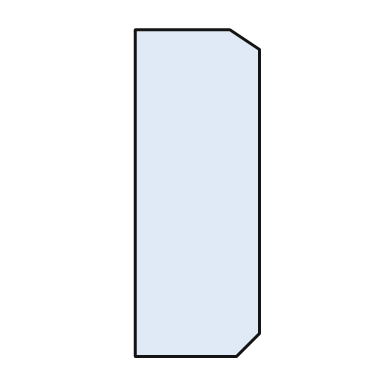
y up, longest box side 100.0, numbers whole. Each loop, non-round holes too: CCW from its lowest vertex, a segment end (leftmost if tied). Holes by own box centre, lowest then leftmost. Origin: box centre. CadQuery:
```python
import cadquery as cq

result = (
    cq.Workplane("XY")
    .moveTo(-19.0, -50.0)
    .lineTo(12.0, -50.0)
    .lineTo(19.0, -43.0)
    .lineTo(19.0, 44.0)
    .lineTo(10.0, 50.0)
    .lineTo(-19.0, 50.0)
    .close()
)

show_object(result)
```